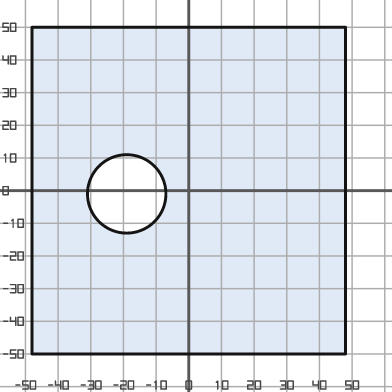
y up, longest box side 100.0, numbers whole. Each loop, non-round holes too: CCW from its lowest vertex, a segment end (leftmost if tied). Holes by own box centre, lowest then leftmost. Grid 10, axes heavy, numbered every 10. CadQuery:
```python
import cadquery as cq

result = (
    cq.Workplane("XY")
    .moveTo(-48.0, -50.0)
    .lineTo(48.0, -50.0)
    .lineTo(48.0, 50.0)
    .lineTo(-48.0, 50.0)
    .close()
    .moveTo(-19.0, -1.0)
    .circle(12.0)
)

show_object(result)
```